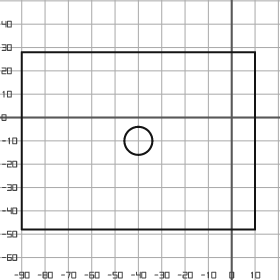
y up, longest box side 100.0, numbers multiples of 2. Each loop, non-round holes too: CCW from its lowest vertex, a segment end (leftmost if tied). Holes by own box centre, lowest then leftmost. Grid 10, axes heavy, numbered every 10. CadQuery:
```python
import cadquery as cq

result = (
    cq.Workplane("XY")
    .moveTo(-90.0, -48.0)
    .lineTo(10.0, -48.0)
    .lineTo(10.0, 28.0)
    .lineTo(-90.0, 28.0)
    .close()
    .moveTo(-40.0, -10.0)
    .circle(6.0)
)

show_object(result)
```